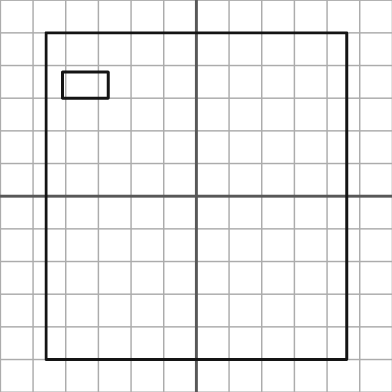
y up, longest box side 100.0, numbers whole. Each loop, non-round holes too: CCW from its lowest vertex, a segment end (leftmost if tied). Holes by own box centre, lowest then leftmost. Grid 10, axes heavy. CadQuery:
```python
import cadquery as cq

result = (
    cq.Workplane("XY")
    .moveTo(-46.0, -50.0)
    .lineTo(46.0, -50.0)
    .lineTo(46.0, 50.0)
    .lineTo(-46.0, 50.0)
    .close()
    .moveTo(-41.0, 30.0)
    .lineTo(-27.0, 30.0)
    .lineTo(-27.0, 38.0)
    .lineTo(-41.0, 38.0)
    .close()
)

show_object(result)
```